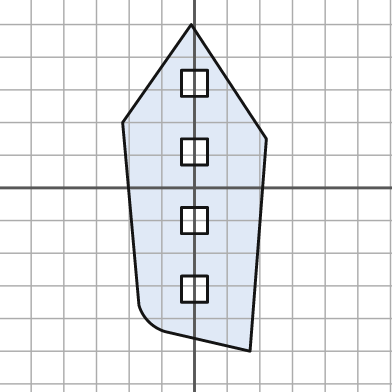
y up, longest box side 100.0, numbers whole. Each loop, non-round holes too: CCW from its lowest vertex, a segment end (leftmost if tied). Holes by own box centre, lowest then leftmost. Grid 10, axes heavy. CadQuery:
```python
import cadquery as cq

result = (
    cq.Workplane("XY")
    .moveTo(17.0, -50.0)
    .lineTo(22.0, 15.0)
    .lineTo(-1.0, 50.0)
    .lineTo(-22.0, 20.0)
    .lineTo(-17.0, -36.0)
    .threePointArc((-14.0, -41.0), (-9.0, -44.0))
    .close()
    .moveTo(-4.0, -35.0)
    .lineTo(4.0, -35.0)
    .lineTo(4.0, -27.0)
    .lineTo(-4.0, -27.0)
    .close()
    .moveTo(-4.0, -14.0)
    .lineTo(4.0, -14.0)
    .lineTo(4.0, -6.0)
    .lineTo(-4.0, -6.0)
    .close()
    .moveTo(-4.0, 7.0)
    .lineTo(4.0, 7.0)
    .lineTo(4.0, 15.0)
    .lineTo(-4.0, 15.0)
    .close()
    .moveTo(-4.0, 28.0)
    .lineTo(4.0, 28.0)
    .lineTo(4.0, 36.0)
    .lineTo(-4.0, 36.0)
    .close()
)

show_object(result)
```